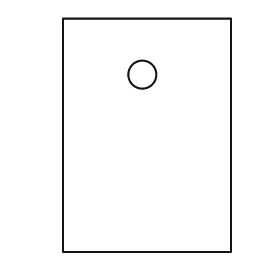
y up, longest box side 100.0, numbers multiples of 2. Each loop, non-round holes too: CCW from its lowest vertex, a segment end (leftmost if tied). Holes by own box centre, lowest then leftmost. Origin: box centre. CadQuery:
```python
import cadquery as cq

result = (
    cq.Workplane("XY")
    .moveTo(-36.0, -50.0)
    .lineTo(36.0, -50.0)
    .lineTo(36.0, 50.0)
    .lineTo(-36.0, 50.0)
    .close()
    .moveTo(-2.0, 26.0)
    .circle(6.0)
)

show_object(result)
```